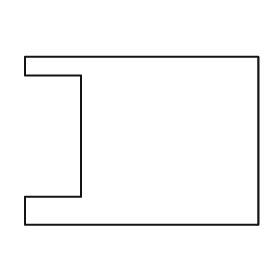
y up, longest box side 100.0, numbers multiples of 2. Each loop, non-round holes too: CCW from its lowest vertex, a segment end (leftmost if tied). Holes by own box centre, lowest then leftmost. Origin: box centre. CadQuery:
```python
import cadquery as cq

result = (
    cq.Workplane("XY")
    .moveTo(-50.0, -36.0)
    .lineTo(50.0, -36.0)
    .lineTo(50.0, 36.0)
    .lineTo(-50.0, 36.0)
    .lineTo(-50.0, 28.0)
    .lineTo(-26.0, 28.0)
    .lineTo(-26.0, -24.0)
    .lineTo(-50.0, -24.0)
    .close()
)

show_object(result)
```